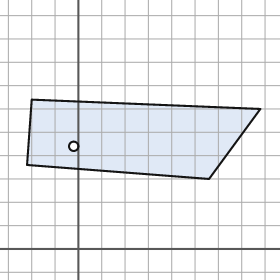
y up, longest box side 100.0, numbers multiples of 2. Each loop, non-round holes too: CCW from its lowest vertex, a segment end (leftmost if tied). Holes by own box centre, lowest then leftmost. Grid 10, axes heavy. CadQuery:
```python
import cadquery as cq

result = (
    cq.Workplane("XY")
    .moveTo(56.0, 30.0)
    .lineTo(78.0, 60.0)
    .lineTo(-20.0, 64.0)
    .lineTo(-22.0, 36.0)
    .close()
    .moveTo(-2.0, 44.0)
    .circle(2.0)
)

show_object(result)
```